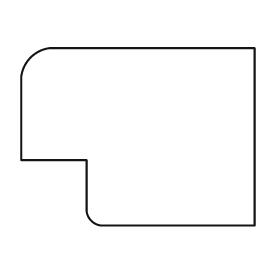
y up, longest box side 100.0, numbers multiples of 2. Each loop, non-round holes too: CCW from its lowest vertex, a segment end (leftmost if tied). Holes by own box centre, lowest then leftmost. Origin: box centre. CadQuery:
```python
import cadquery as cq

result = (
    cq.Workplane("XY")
    .moveTo(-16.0, -38.0)
    .lineTo(50.0, -38.0)
    .lineTo(50.0, 38.0)
    .lineTo(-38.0, 38.0)
    .threePointArc((-46.0, 34.0), (-50.0, 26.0))
    .lineTo(-50.0, -10.0)
    .lineTo(-22.0, -10.0)
    .lineTo(-22.0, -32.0)
    .threePointArc((-20.0, -36.0), (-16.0, -38.0))
    .close()
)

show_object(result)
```